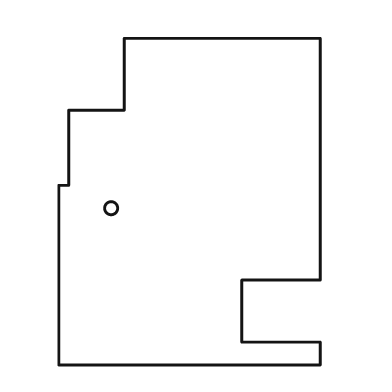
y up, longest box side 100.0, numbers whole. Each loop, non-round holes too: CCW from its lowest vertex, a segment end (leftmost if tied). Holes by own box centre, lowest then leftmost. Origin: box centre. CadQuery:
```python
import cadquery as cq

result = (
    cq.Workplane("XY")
    .moveTo(-40.0, -50.0)
    .lineTo(40.0, -50.0)
    .lineTo(40.0, -43.0)
    .lineTo(16.0, -43.0)
    .lineTo(16.0, -24.0)
    .lineTo(40.0, -24.0)
    .lineTo(40.0, 50.0)
    .lineTo(-20.0, 50.0)
    .lineTo(-20.0, 28.0)
    .lineTo(-37.0, 28.0)
    .lineTo(-37.0, 5.0)
    .lineTo(-40.0, 5.0)
    .close()
    .moveTo(-24.0, -2.0)
    .circle(2.0)
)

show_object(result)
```